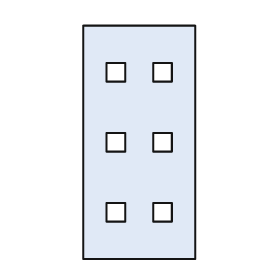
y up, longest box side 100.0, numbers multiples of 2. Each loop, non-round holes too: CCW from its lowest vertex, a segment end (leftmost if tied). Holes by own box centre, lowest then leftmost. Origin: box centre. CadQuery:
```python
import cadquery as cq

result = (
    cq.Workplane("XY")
    .moveTo(-24.0, -50.0)
    .lineTo(24.0, -50.0)
    .lineTo(24.0, 50.0)
    .lineTo(-24.0, 50.0)
    .close()
    .moveTo(-14.0, -34.0)
    .lineTo(-6.0, -34.0)
    .lineTo(-6.0, -26.0)
    .lineTo(-14.0, -26.0)
    .close()
    .moveTo(6.0, -34.0)
    .lineTo(14.0, -34.0)
    .lineTo(14.0, -26.0)
    .lineTo(6.0, -26.0)
    .close()
    .moveTo(-14.0, -4.0)
    .lineTo(-6.0, -4.0)
    .lineTo(-6.0, 4.0)
    .lineTo(-14.0, 4.0)
    .close()
    .moveTo(6.0, -4.0)
    .lineTo(14.0, -4.0)
    .lineTo(14.0, 4.0)
    .lineTo(6.0, 4.0)
    .close()
    .moveTo(-14.0, 26.0)
    .lineTo(-6.0, 26.0)
    .lineTo(-6.0, 34.0)
    .lineTo(-14.0, 34.0)
    .close()
    .moveTo(6.0, 26.0)
    .lineTo(14.0, 26.0)
    .lineTo(14.0, 34.0)
    .lineTo(6.0, 34.0)
    .close()
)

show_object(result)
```